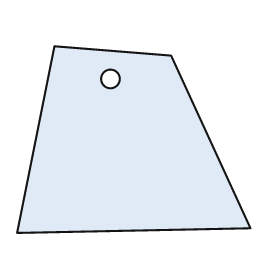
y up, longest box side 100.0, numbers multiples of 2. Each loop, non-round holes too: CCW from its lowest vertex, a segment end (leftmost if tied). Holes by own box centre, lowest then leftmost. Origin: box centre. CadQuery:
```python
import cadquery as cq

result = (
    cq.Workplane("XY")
    .moveTo(-50.0, -40.0)
    .lineTo(50.0, -38.0)
    .lineTo(16.0, 36.0)
    .lineTo(-34.0, 40.0)
    .close()
    .moveTo(-10.0, 26.0)
    .circle(4.0)
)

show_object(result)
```